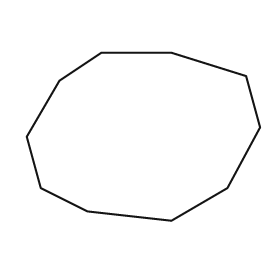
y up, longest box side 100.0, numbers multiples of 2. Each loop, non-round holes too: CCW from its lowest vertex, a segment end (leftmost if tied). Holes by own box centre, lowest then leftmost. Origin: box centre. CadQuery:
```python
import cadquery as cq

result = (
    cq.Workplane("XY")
    .moveTo(12.0, -36.0)
    .lineTo(36.0, -22.0)
    .lineTo(50.0, 4.0)
    .lineTo(44.0, 26.0)
    .lineTo(12.0, 36.0)
    .lineTo(-18.0, 36.0)
    .lineTo(-36.0, 24.0)
    .lineTo(-50.0, 0.0)
    .lineTo(-44.0, -22.0)
    .lineTo(-24.0, -32.0)
    .close()
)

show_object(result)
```